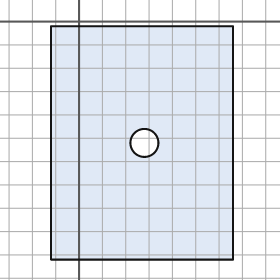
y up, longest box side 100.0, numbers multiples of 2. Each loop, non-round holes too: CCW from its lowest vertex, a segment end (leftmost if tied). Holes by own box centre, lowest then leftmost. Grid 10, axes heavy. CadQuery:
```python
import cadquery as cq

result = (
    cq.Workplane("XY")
    .moveTo(-12.0, -102.0)
    .lineTo(66.0, -102.0)
    .lineTo(66.0, -2.0)
    .lineTo(-12.0, -2.0)
    .close()
    .moveTo(28.0, -52.0)
    .circle(6.0)
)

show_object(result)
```